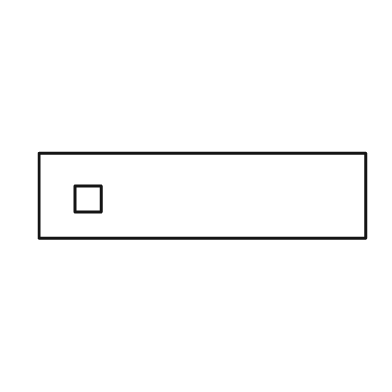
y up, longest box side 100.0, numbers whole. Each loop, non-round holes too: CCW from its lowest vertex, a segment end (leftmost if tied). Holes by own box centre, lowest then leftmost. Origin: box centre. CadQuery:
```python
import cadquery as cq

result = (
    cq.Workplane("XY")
    .moveTo(-50.0, -13.0)
    .lineTo(50.0, -13.0)
    .lineTo(50.0, 13.0)
    .lineTo(-50.0, 13.0)
    .close()
    .moveTo(-39.0, -5.0)
    .lineTo(-31.0, -5.0)
    .lineTo(-31.0, 3.0)
    .lineTo(-39.0, 3.0)
    .close()
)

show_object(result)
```